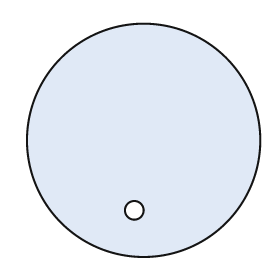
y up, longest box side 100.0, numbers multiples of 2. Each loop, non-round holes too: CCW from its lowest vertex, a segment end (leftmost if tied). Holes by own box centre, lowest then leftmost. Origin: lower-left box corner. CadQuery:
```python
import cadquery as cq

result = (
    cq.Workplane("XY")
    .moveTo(50.0, 50.0)
    .circle(50.0)
    .moveTo(46.0, 20.0)
    .circle(4.0)
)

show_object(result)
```